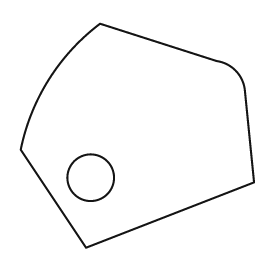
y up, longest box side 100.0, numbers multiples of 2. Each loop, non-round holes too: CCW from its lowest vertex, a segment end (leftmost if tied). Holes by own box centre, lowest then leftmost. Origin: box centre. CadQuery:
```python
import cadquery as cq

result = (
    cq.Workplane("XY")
    .moveTo(-22.0, -48.0)
    .lineTo(50.0, -20.0)
    .lineTo(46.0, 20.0)
    .threePointArc((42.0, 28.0), (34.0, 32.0))
    .lineTo(-16.0, 48.0)
    .threePointArc((-38.0, 24.0), (-50.0, -6.0))
    .close()
    .moveTo(-20.0, -18.0)
    .circle(10.0)
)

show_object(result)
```